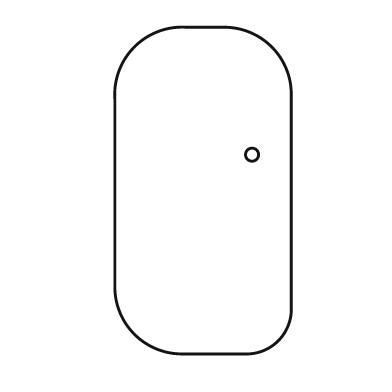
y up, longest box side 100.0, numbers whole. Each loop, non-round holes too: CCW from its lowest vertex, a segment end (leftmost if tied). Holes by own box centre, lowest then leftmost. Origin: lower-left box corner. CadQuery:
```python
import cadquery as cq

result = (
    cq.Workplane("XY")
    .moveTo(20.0, 0.0)
    .lineTo(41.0, 0.0)
    .threePointArc((50.0, 4.0), (54.0, 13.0))
    .lineTo(54.0, 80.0)
    .threePointArc((48.0, 94.0), (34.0, 100.0))
    .lineTo(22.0, 100.0)
    .threePointArc((6.0, 94.0), (0.0, 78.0))
    .lineTo(0.0, 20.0)
    .threePointArc((6.0, 6.0), (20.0, 0.0))
    .close()
    .moveTo(42.0, 61.0)
    .circle(2.0)
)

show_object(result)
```